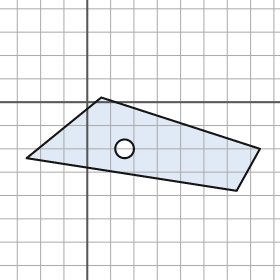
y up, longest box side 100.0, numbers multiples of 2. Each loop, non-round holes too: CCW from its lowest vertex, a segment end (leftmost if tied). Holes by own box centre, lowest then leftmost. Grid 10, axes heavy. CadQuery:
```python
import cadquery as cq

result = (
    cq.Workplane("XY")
    .moveTo(64.0, -38.0)
    .lineTo(74.0, -20.0)
    .lineTo(6.0, 2.0)
    .lineTo(-26.0, -24.0)
    .close()
    .moveTo(16.0, -20.0)
    .circle(4.0)
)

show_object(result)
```